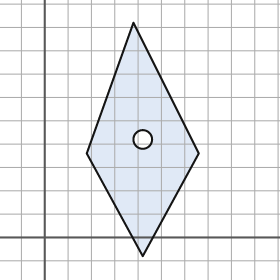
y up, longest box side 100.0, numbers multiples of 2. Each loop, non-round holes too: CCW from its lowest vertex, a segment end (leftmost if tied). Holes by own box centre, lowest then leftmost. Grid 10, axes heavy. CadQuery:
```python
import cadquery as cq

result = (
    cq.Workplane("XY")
    .moveTo(42.0, -8.0)
    .lineTo(66.0, 36.0)
    .lineTo(38.0, 92.0)
    .lineTo(18.0, 36.0)
    .close()
    .moveTo(42.0, 42.0)
    .circle(4.0)
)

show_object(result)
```